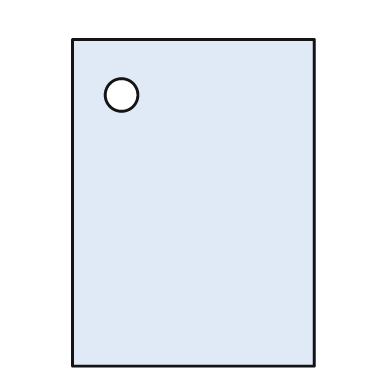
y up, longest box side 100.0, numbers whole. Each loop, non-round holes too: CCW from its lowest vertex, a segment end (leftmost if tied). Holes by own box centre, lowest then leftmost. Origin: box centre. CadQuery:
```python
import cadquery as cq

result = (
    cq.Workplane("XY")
    .moveTo(-37.0, -50.0)
    .lineTo(37.0, -50.0)
    .lineTo(37.0, 50.0)
    .lineTo(-37.0, 50.0)
    .close()
    .moveTo(-22.0, 33.0)
    .circle(5.0)
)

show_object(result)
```